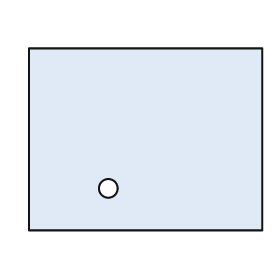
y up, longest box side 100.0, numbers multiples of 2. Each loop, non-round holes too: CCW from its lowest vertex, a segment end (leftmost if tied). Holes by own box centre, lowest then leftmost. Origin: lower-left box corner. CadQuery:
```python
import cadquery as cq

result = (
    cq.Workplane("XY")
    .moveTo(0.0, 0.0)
    .lineTo(100.0, 0.0)
    .lineTo(100.0, 78.0)
    .lineTo(0.0, 78.0)
    .close()
    .moveTo(34.0, 18.0)
    .circle(4.0)
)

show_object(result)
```